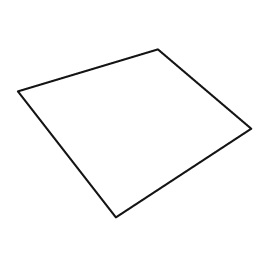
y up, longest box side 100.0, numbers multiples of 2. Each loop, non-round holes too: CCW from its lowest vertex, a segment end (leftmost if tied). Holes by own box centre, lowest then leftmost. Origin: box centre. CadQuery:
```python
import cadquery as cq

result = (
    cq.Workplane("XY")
    .moveTo(-8.0, -36.0)
    .lineTo(50.0, 2.0)
    .lineTo(10.0, 36.0)
    .lineTo(-50.0, 18.0)
    .close()
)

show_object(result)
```